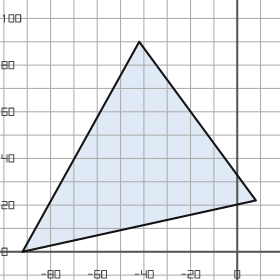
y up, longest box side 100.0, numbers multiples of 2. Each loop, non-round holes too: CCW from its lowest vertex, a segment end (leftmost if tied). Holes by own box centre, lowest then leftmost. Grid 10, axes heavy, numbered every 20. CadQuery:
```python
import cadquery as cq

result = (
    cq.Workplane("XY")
    .moveTo(-92.0, 0.0)
    .lineTo(8.0, 22.0)
    .lineTo(-42.0, 90.0)
    .close()
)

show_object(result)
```